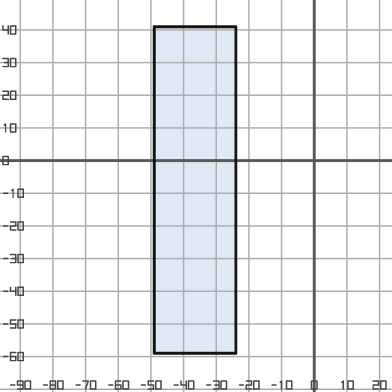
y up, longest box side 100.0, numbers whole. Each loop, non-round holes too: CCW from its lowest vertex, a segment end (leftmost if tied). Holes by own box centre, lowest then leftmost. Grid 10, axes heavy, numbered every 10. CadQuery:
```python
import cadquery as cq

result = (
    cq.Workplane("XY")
    .moveTo(-49.0, -59.0)
    .lineTo(-24.0, -59.0)
    .lineTo(-24.0, 41.0)
    .lineTo(-49.0, 41.0)
    .close()
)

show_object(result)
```